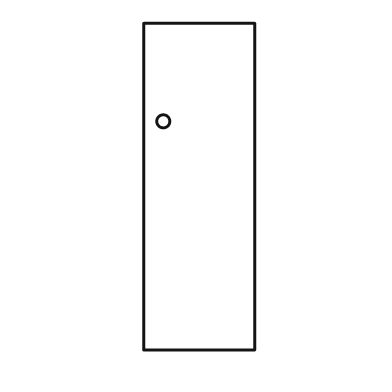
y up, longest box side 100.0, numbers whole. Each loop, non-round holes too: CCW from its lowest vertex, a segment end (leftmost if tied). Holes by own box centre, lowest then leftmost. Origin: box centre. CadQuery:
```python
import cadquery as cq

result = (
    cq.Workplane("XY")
    .moveTo(-17.0, -50.0)
    .lineTo(17.0, -50.0)
    .lineTo(17.0, 50.0)
    .lineTo(-17.0, 50.0)
    .close()
    .moveTo(-11.0, 20.0)
    .circle(2.0)
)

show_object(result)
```